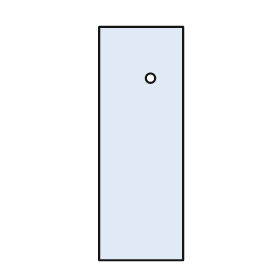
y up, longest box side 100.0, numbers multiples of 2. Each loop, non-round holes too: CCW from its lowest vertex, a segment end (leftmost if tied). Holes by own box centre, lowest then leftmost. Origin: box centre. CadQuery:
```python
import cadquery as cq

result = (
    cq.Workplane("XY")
    .moveTo(-18.0, -50.0)
    .lineTo(18.0, -50.0)
    .lineTo(18.0, 50.0)
    .lineTo(-18.0, 50.0)
    .close()
    .moveTo(4.0, 28.0)
    .circle(2.0)
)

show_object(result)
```